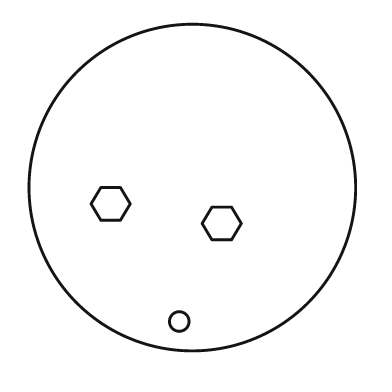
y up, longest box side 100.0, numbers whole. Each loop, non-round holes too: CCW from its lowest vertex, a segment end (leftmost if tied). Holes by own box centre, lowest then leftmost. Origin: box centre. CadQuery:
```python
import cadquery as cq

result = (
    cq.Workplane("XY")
    .moveTo(0.0, 0.0)
    .circle(50.0)
    .moveTo(-4.0, -41.0)
    .circle(3.0)
    .moveTo(6.0, -16.0)
    .lineTo(12.0, -16.0)
    .lineTo(15.0, -11.0)
    .lineTo(12.0, -6.0)
    .lineTo(6.0, -6.0)
    .lineTo(3.0, -11.0)
    .close()
    .moveTo(-28.0, -10.0)
    .lineTo(-22.0, -10.0)
    .lineTo(-19.0, -5.0)
    .lineTo(-22.0, 0.0)
    .lineTo(-28.0, 0.0)
    .lineTo(-31.0, -5.0)
    .close()
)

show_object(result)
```